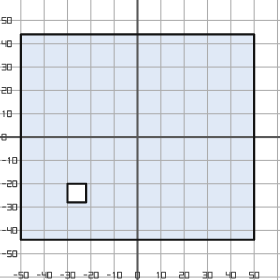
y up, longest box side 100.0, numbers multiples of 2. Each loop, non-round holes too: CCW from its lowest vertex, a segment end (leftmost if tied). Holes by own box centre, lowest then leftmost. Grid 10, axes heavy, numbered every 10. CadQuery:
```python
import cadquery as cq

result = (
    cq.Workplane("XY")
    .moveTo(-50.0, -44.0)
    .lineTo(50.0, -44.0)
    .lineTo(50.0, 44.0)
    .lineTo(-50.0, 44.0)
    .close()
    .moveTo(-30.0, -28.0)
    .lineTo(-22.0, -28.0)
    .lineTo(-22.0, -20.0)
    .lineTo(-30.0, -20.0)
    .close()
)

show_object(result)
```